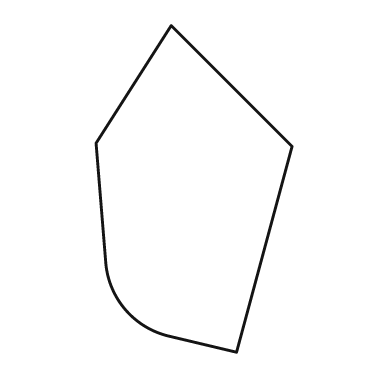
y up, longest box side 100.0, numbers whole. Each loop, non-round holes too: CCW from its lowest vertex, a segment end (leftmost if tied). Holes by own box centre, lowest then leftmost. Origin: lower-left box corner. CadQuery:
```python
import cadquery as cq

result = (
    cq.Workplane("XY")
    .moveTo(43.0, 0.0)
    .lineTo(60.0, 63.0)
    .lineTo(23.0, 100.0)
    .lineTo(0.0, 64.0)
    .lineTo(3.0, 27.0)
    .threePointArc((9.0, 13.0), (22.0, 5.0))
    .close()
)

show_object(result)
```